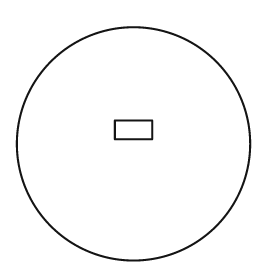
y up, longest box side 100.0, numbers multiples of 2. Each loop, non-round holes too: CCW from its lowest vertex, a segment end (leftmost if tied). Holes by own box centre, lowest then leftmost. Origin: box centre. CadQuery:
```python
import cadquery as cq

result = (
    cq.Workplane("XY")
    .moveTo(0.0, 0.0)
    .circle(50.0)
    .moveTo(-8.0, 2.0)
    .lineTo(8.0, 2.0)
    .lineTo(8.0, 10.0)
    .lineTo(-8.0, 10.0)
    .close()
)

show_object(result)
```